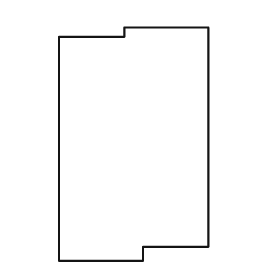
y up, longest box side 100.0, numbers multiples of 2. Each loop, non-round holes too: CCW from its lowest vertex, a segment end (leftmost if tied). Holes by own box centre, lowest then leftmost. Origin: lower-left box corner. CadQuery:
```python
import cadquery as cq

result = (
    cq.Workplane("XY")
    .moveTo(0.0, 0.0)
    .lineTo(36.0, 0.0)
    .lineTo(36.0, 6.0)
    .lineTo(64.0, 6.0)
    .lineTo(64.0, 100.0)
    .lineTo(28.0, 100.0)
    .lineTo(28.0, 96.0)
    .lineTo(0.0, 96.0)
    .close()
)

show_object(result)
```